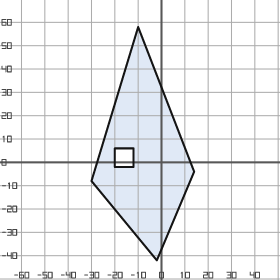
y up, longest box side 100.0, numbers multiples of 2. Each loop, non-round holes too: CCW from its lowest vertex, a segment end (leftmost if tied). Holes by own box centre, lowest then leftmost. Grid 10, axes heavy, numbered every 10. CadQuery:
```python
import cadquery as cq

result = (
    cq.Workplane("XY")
    .moveTo(-2.0, -42.0)
    .lineTo(14.0, -4.0)
    .lineTo(-10.0, 58.0)
    .lineTo(-30.0, -8.0)
    .close()
    .moveTo(-20.0, -2.0)
    .lineTo(-12.0, -2.0)
    .lineTo(-12.0, 6.0)
    .lineTo(-20.0, 6.0)
    .close()
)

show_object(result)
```